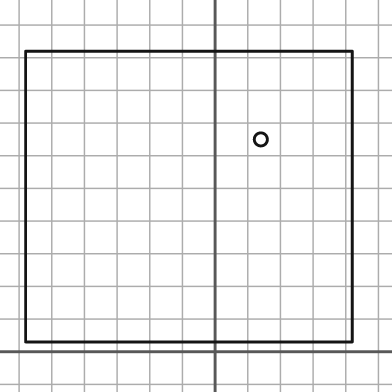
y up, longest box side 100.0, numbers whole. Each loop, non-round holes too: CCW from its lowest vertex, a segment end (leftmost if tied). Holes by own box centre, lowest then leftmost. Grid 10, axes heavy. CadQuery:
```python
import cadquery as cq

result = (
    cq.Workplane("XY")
    .moveTo(-58.0, 3.0)
    .lineTo(42.0, 3.0)
    .lineTo(42.0, 92.0)
    .lineTo(-58.0, 92.0)
    .close()
    .moveTo(14.0, 65.0)
    .circle(2.0)
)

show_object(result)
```